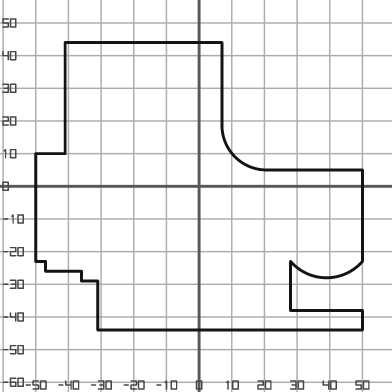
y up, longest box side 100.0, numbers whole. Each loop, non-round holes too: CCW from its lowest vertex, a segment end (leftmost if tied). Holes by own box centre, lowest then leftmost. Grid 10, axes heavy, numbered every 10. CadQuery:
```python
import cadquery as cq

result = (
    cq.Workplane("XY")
    .moveTo(-31.0, -44.0)
    .lineTo(50.0, -44.0)
    .lineTo(50.0, -38.0)
    .lineTo(28.0, -38.0)
    .lineTo(28.0, -23.0)
    .threePointArc((39.0, -28.0), (50.0, -23.0))
    .lineTo(50.0, 5.0)
    .lineTo(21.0, 5.0)
    .threePointArc((11.0, 9.0), (7.0, 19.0))
    .lineTo(7.0, 44.0)
    .lineTo(-41.0, 44.0)
    .lineTo(-41.0, 10.0)
    .lineTo(-50.0, 10.0)
    .lineTo(-50.0, -23.0)
    .lineTo(-47.0, -23.0)
    .lineTo(-47.0, -26.0)
    .lineTo(-36.0, -26.0)
    .lineTo(-36.0, -29.0)
    .lineTo(-31.0, -29.0)
    .close()
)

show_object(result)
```